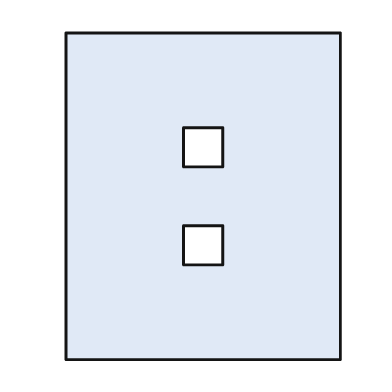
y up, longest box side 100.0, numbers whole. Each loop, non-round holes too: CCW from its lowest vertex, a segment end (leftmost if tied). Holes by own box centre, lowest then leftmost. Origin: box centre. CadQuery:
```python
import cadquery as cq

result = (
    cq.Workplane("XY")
    .moveTo(-42.0, -50.0)
    .lineTo(42.0, -50.0)
    .lineTo(42.0, 50.0)
    .lineTo(-42.0, 50.0)
    .close()
    .moveTo(-6.0, -21.0)
    .lineTo(6.0, -21.0)
    .lineTo(6.0, -9.0)
    .lineTo(-6.0, -9.0)
    .close()
    .moveTo(-6.0, 9.0)
    .lineTo(6.0, 9.0)
    .lineTo(6.0, 21.0)
    .lineTo(-6.0, 21.0)
    .close()
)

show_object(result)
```